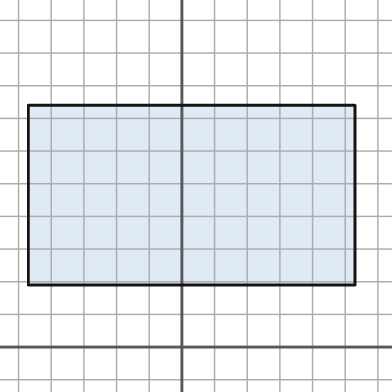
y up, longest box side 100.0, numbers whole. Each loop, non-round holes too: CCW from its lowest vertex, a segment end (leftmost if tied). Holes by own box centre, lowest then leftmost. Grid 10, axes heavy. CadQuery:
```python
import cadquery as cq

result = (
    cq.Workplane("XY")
    .moveTo(-47.0, 19.0)
    .lineTo(53.0, 19.0)
    .lineTo(53.0, 74.0)
    .lineTo(-47.0, 74.0)
    .close()
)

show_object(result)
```